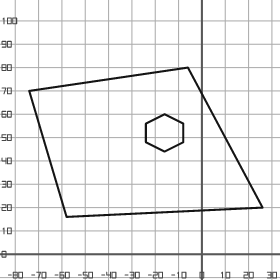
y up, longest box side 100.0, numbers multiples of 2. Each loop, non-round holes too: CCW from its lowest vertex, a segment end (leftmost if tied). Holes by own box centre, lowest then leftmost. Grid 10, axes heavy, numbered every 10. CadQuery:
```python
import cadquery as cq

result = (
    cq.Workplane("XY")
    .moveTo(-58.0, 16.0)
    .lineTo(26.0, 20.0)
    .lineTo(-6.0, 80.0)
    .lineTo(-74.0, 70.0)
    .close()
    .moveTo(-16.0, 44.0)
    .lineTo(-8.0, 48.0)
    .lineTo(-8.0, 56.0)
    .lineTo(-16.0, 60.0)
    .lineTo(-24.0, 56.0)
    .lineTo(-24.0, 48.0)
    .close()
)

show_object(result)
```